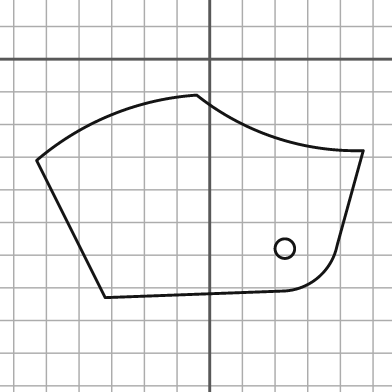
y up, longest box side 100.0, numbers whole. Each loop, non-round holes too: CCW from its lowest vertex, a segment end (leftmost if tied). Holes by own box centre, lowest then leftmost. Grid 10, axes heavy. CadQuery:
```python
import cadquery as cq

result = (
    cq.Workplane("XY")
    .moveTo(-32.0, -73.0)
    .lineTo(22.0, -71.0)
    .threePointArc((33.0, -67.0), (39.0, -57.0))
    .lineTo(47.0, -28.0)
    .threePointArc((20.0, -24.0), (-4.0, -11.0))
    .threePointArc((-30.0, -17.0), (-53.0, -31.0))
    .close()
    .moveTo(23.0, -58.0)
    .circle(3.0)
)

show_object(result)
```